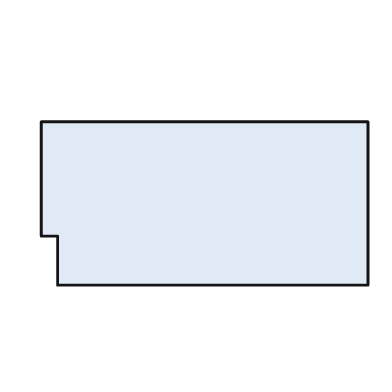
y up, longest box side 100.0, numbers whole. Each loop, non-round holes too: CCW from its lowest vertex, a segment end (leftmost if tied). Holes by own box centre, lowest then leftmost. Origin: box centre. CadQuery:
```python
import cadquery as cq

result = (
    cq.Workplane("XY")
    .moveTo(-45.0, -25.0)
    .lineTo(50.0, -25.0)
    .lineTo(50.0, 25.0)
    .lineTo(-50.0, 25.0)
    .lineTo(-50.0, -10.0)
    .lineTo(-45.0, -10.0)
    .close()
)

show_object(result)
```